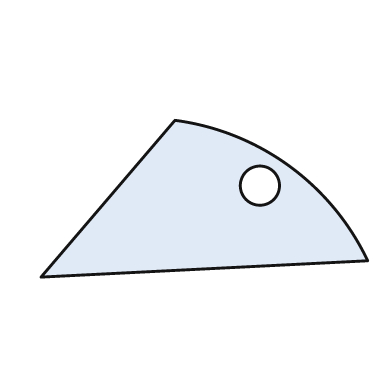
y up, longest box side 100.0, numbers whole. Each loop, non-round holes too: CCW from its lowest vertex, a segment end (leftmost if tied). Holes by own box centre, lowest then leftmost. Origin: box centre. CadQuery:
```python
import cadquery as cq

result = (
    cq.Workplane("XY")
    .moveTo(-50.0, -24.0)
    .lineTo(50.0, -19.0)
    .threePointArc((26.0, 10.0), (-9.0, 24.0))
    .close()
    .moveTo(17.0, 4.0)
    .circle(6.0)
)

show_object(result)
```